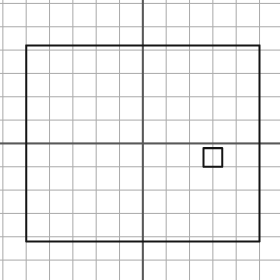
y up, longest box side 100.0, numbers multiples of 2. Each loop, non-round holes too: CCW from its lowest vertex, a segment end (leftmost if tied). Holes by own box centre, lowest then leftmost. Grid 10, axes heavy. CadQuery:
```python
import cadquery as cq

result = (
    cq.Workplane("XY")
    .moveTo(-50.0, -42.0)
    .lineTo(50.0, -42.0)
    .lineTo(50.0, 42.0)
    .lineTo(-50.0, 42.0)
    .close()
    .moveTo(26.0, -10.0)
    .lineTo(34.0, -10.0)
    .lineTo(34.0, -2.0)
    .lineTo(26.0, -2.0)
    .close()
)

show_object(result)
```